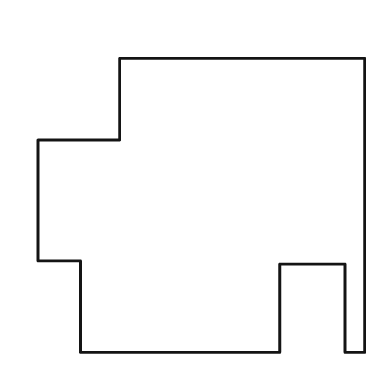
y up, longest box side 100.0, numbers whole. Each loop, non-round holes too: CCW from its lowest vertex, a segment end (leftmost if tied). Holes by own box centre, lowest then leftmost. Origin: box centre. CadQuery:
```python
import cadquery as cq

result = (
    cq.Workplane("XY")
    .moveTo(-37.0, -45.0)
    .lineTo(24.0, -45.0)
    .lineTo(24.0, -18.0)
    .lineTo(44.0, -18.0)
    .lineTo(44.0, -45.0)
    .lineTo(50.0, -45.0)
    .lineTo(50.0, 45.0)
    .lineTo(-25.0, 45.0)
    .lineTo(-25.0, 20.0)
    .lineTo(-50.0, 20.0)
    .lineTo(-50.0, -17.0)
    .lineTo(-37.0, -17.0)
    .close()
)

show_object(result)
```